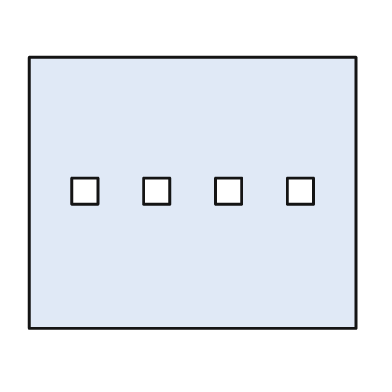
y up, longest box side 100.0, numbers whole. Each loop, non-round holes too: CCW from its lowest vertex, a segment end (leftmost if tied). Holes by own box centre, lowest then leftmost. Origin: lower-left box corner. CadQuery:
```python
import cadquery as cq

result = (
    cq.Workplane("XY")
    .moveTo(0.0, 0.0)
    .lineTo(100.0, 0.0)
    .lineTo(100.0, 83.0)
    .lineTo(0.0, 83.0)
    .close()
    .moveTo(13.0, 38.0)
    .lineTo(21.0, 38.0)
    .lineTo(21.0, 46.0)
    .lineTo(13.0, 46.0)
    .close()
    .moveTo(35.0, 38.0)
    .lineTo(43.0, 38.0)
    .lineTo(43.0, 46.0)
    .lineTo(35.0, 46.0)
    .close()
    .moveTo(57.0, 38.0)
    .lineTo(65.0, 38.0)
    .lineTo(65.0, 46.0)
    .lineTo(57.0, 46.0)
    .close()
    .moveTo(79.0, 38.0)
    .lineTo(87.0, 38.0)
    .lineTo(87.0, 46.0)
    .lineTo(79.0, 46.0)
    .close()
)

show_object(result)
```